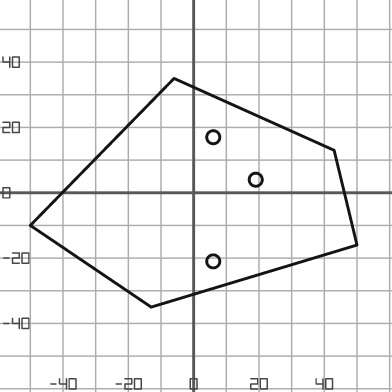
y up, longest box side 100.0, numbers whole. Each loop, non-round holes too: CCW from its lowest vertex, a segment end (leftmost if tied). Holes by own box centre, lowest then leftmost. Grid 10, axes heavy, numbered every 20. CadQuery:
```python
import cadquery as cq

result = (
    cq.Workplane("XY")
    .moveTo(-13.0, -35.0)
    .lineTo(50.0, -16.0)
    .lineTo(43.0, 13.0)
    .lineTo(-6.0, 35.0)
    .lineTo(-50.0, -10.0)
    .close()
    .moveTo(6.0, -21.0)
    .circle(2.0)
    .moveTo(19.0, 4.0)
    .circle(2.0)
    .moveTo(6.0, 17.0)
    .circle(2.0)
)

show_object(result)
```